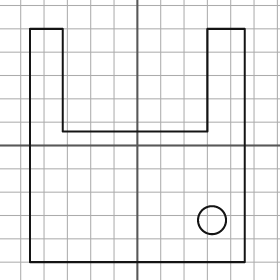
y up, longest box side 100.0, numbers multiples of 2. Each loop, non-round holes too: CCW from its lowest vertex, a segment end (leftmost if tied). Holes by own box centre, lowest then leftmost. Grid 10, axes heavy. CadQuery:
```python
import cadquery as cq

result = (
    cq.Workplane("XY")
    .moveTo(-46.0, -50.0)
    .lineTo(46.0, -50.0)
    .lineTo(46.0, 50.0)
    .lineTo(30.0, 50.0)
    .lineTo(30.0, 6.0)
    .lineTo(-32.0, 6.0)
    .lineTo(-32.0, 50.0)
    .lineTo(-46.0, 50.0)
    .close()
    .moveTo(32.0, -32.0)
    .circle(6.0)
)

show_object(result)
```